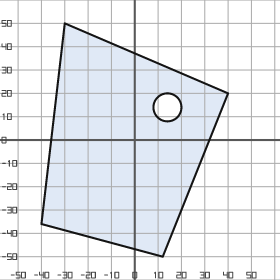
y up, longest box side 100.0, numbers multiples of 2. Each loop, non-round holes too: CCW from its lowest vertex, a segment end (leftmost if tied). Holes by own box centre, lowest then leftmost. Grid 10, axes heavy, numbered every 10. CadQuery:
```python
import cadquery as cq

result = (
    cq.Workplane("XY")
    .moveTo(12.0, -50.0)
    .lineTo(40.0, 20.0)
    .lineTo(-30.0, 50.0)
    .lineTo(-40.0, -36.0)
    .close()
    .moveTo(14.0, 14.0)
    .circle(6.0)
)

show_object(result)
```